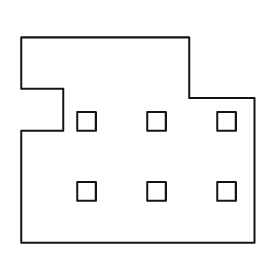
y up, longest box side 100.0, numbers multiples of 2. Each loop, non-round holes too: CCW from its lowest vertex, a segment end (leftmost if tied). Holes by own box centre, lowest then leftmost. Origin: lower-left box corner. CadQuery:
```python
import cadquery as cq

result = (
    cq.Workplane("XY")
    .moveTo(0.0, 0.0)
    .lineTo(100.0, 0.0)
    .lineTo(100.0, 62.0)
    .lineTo(72.0, 62.0)
    .lineTo(72.0, 88.0)
    .lineTo(0.0, 88.0)
    .lineTo(0.0, 66.0)
    .lineTo(18.0, 66.0)
    .lineTo(18.0, 48.0)
    .lineTo(0.0, 48.0)
    .close()
    .moveTo(24.0, 18.0)
    .lineTo(32.0, 18.0)
    .lineTo(32.0, 26.0)
    .lineTo(24.0, 26.0)
    .close()
    .moveTo(54.0, 18.0)
    .lineTo(62.0, 18.0)
    .lineTo(62.0, 26.0)
    .lineTo(54.0, 26.0)
    .close()
    .moveTo(84.0, 18.0)
    .lineTo(92.0, 18.0)
    .lineTo(92.0, 26.0)
    .lineTo(84.0, 26.0)
    .close()
    .moveTo(24.0, 48.0)
    .lineTo(32.0, 48.0)
    .lineTo(32.0, 56.0)
    .lineTo(24.0, 56.0)
    .close()
    .moveTo(54.0, 48.0)
    .lineTo(62.0, 48.0)
    .lineTo(62.0, 56.0)
    .lineTo(54.0, 56.0)
    .close()
    .moveTo(84.0, 48.0)
    .lineTo(92.0, 48.0)
    .lineTo(92.0, 56.0)
    .lineTo(84.0, 56.0)
    .close()
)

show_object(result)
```